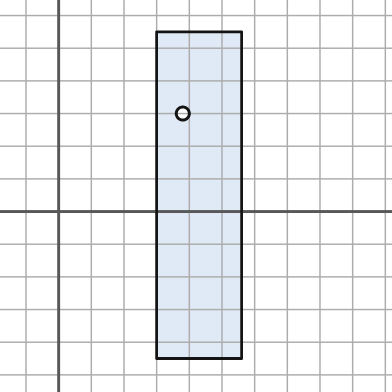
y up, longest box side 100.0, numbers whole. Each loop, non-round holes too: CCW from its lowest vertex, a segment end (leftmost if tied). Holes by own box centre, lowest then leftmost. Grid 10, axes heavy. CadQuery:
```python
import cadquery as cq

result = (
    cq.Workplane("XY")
    .moveTo(30.0, -45.0)
    .lineTo(56.0, -45.0)
    .lineTo(56.0, 55.0)
    .lineTo(30.0, 55.0)
    .close()
    .moveTo(38.0, 30.0)
    .circle(2.0)
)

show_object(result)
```